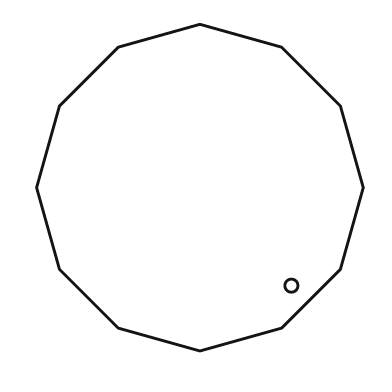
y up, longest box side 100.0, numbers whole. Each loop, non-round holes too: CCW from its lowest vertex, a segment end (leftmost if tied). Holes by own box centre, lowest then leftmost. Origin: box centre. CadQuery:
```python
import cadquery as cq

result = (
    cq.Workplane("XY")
    .moveTo(0.0, -50.0)
    .lineTo(25.0, -43.0)
    .lineTo(43.0, -25.0)
    .lineTo(50.0, 0.0)
    .lineTo(43.0, 25.0)
    .lineTo(25.0, 43.0)
    .lineTo(0.0, 50.0)
    .lineTo(-25.0, 43.0)
    .lineTo(-43.0, 25.0)
    .lineTo(-50.0, 0.0)
    .lineTo(-43.0, -25.0)
    .lineTo(-25.0, -43.0)
    .close()
    .moveTo(28.0, -30.0)
    .circle(2.0)
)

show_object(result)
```